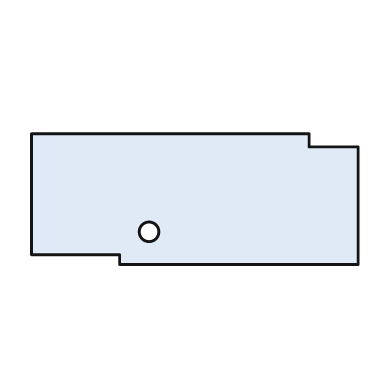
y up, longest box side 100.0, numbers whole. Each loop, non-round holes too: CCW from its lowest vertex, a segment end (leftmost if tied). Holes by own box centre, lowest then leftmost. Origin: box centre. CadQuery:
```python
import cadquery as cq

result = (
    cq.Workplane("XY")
    .moveTo(-23.0, -20.0)
    .lineTo(50.0, -20.0)
    .lineTo(50.0, 16.0)
    .lineTo(35.0, 16.0)
    .lineTo(35.0, 20.0)
    .lineTo(-50.0, 20.0)
    .lineTo(-50.0, -17.0)
    .lineTo(-23.0, -17.0)
    .close()
    .moveTo(-14.0, -10.0)
    .circle(3.0)
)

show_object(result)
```